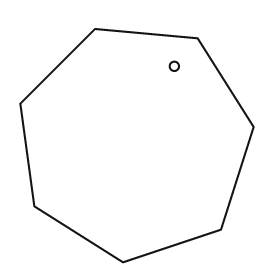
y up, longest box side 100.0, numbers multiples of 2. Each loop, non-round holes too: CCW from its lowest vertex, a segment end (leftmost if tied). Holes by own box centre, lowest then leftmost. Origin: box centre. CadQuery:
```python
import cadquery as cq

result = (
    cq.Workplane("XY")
    .moveTo(-6.0, -50.0)
    .lineTo(36.0, -36.0)
    .lineTo(50.0, 8.0)
    .lineTo(26.0, 46.0)
    .lineTo(-18.0, 50.0)
    .lineTo(-50.0, 18.0)
    .lineTo(-44.0, -26.0)
    .close()
    .moveTo(16.0, 34.0)
    .circle(2.0)
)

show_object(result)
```